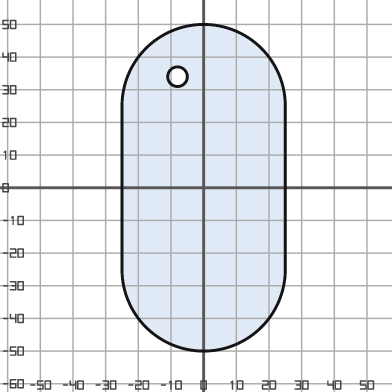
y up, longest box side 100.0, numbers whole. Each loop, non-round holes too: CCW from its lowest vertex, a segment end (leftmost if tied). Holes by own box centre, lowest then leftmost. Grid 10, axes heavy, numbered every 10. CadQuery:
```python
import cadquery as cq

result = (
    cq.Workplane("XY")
    .moveTo(-25.0, -25.0)
    .threePointArc((0.0, -50.0), (25.0, -25.0))
    .lineTo(25.0, 25.0)
    .threePointArc((0.0, 50.0), (-25.0, 25.0))
    .close()
    .moveTo(-8.0, 34.0)
    .circle(3.0)
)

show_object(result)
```